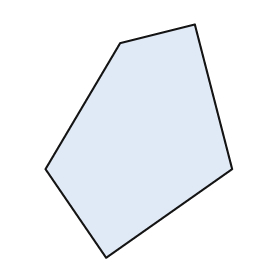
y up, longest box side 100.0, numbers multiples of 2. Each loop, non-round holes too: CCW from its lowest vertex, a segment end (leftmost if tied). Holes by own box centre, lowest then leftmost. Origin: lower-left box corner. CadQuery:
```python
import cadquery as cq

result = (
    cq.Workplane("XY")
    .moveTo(26.0, 0.0)
    .lineTo(80.0, 38.0)
    .lineTo(64.0, 100.0)
    .lineTo(32.0, 92.0)
    .lineTo(0.0, 38.0)
    .close()
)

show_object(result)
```